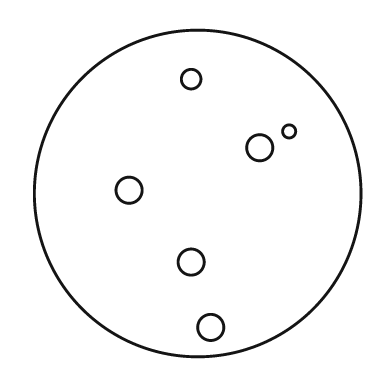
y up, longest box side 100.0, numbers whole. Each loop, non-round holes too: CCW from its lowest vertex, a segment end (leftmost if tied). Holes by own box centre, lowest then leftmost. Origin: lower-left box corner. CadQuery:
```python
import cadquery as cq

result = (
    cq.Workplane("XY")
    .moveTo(50.0, 50.0)
    .circle(50.0)
    .moveTo(54.0, 9.0)
    .circle(4.0)
    .moveTo(48.0, 29.0)
    .circle(4.0)
    .moveTo(29.0, 51.0)
    .circle(4.0)
    .moveTo(69.0, 64.0)
    .circle(4.0)
    .moveTo(78.0, 69.0)
    .circle(2.0)
    .moveTo(48.0, 85.0)
    .circle(3.0)
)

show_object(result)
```